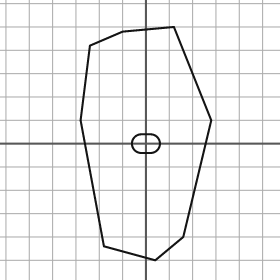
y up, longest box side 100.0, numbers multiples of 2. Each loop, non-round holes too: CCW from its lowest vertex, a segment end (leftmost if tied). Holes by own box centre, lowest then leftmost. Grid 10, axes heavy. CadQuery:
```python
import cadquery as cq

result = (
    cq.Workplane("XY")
    .moveTo(4.0, -50.0)
    .lineTo(16.0, -40.0)
    .lineTo(28.0, 10.0)
    .lineTo(12.0, 50.0)
    .lineTo(-10.0, 48.0)
    .lineTo(-24.0, 42.0)
    .lineTo(-28.0, 10.0)
    .lineTo(-18.0, -44.0)
    .close()
    .moveTo(-2.0, -4.0)
    .lineTo(2.0, -4.0)
    .threePointArc((6.0, 0.0), (2.0, 4.0))
    .lineTo(-2.0, 4.0)
    .threePointArc((-6.0, 0.0), (-2.0, -4.0))
    .close()
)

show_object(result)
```